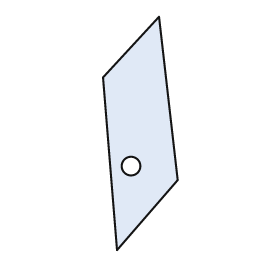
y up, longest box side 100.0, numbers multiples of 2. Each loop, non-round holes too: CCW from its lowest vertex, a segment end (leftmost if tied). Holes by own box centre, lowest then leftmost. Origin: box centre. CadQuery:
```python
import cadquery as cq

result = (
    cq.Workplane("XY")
    .moveTo(-10.0, -50.0)
    .lineTo(16.0, -20.0)
    .lineTo(8.0, 50.0)
    .lineTo(-16.0, 24.0)
    .close()
    .moveTo(-4.0, -14.0)
    .circle(4.0)
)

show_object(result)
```